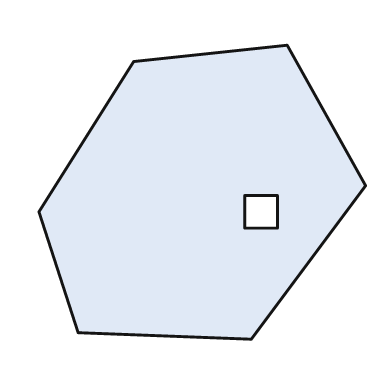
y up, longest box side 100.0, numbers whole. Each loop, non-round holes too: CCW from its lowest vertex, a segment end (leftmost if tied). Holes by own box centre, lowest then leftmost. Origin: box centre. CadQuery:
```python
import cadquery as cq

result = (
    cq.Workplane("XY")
    .moveTo(15.0, -45.0)
    .lineTo(50.0, 2.0)
    .lineTo(26.0, 45.0)
    .lineTo(-21.0, 40.0)
    .lineTo(-50.0, -6.0)
    .lineTo(-38.0, -43.0)
    .close()
    .moveTo(13.0, -11.0)
    .lineTo(23.0, -11.0)
    .lineTo(23.0, -1.0)
    .lineTo(13.0, -1.0)
    .close()
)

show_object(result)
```